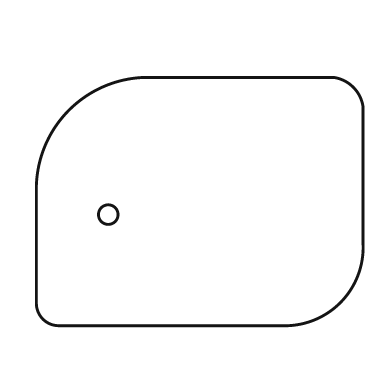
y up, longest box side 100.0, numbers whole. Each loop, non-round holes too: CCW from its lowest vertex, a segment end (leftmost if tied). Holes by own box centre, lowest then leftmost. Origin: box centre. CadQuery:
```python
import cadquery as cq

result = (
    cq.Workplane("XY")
    .moveTo(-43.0, -38.0)
    .lineTo(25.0, -38.0)
    .threePointArc((43.0, -31.0), (50.0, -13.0))
    .lineTo(50.0, 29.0)
    .threePointArc((47.0, 35.0), (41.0, 38.0))
    .lineTo(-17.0, 38.0)
    .threePointArc((-40.0, 28.0), (-50.0, 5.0))
    .lineTo(-50.0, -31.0)
    .threePointArc((-48.0, -36.0), (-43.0, -38.0))
    .close()
    .moveTo(-28.0, -4.0)
    .circle(3.0)
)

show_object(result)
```